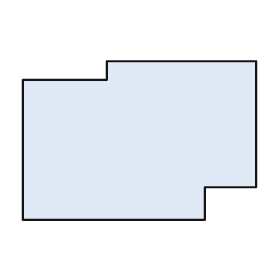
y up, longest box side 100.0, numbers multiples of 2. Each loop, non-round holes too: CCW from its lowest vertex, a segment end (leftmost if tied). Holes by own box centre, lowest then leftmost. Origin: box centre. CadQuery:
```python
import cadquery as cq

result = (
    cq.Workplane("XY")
    .moveTo(-50.0, -34.0)
    .lineTo(28.0, -34.0)
    .lineTo(28.0, -20.0)
    .lineTo(50.0, -20.0)
    .lineTo(50.0, 34.0)
    .lineTo(-14.0, 34.0)
    .lineTo(-14.0, 26.0)
    .lineTo(-50.0, 26.0)
    .close()
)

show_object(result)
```